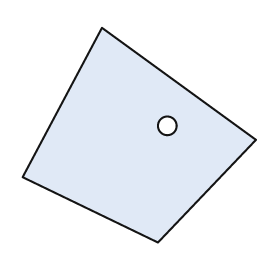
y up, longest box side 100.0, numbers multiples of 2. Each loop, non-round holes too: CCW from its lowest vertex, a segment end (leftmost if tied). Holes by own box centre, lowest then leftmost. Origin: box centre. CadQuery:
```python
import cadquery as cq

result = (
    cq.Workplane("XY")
    .moveTo(8.0, -46.0)
    .lineTo(50.0, -2.0)
    .lineTo(-16.0, 46.0)
    .lineTo(-50.0, -18.0)
    .close()
    .moveTo(12.0, 4.0)
    .circle(4.0)
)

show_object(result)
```